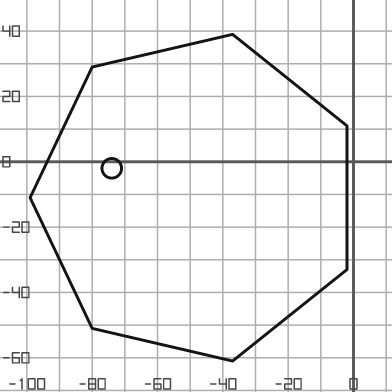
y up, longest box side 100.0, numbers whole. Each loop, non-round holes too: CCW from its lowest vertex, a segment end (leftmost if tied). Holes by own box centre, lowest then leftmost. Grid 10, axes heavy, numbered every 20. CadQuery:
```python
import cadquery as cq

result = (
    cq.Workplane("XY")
    .moveTo(-37.0, -61.0)
    .lineTo(-2.0, -33.0)
    .lineTo(-2.0, 11.0)
    .lineTo(-37.0, 39.0)
    .lineTo(-80.0, 29.0)
    .lineTo(-99.0, -11.0)
    .lineTo(-80.0, -51.0)
    .close()
    .moveTo(-74.0, -2.0)
    .circle(3.0)
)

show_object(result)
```